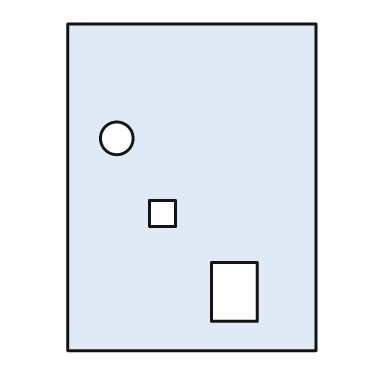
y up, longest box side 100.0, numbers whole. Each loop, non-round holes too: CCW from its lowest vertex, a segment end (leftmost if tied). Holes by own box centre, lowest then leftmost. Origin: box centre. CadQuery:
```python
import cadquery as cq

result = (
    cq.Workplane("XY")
    .moveTo(-38.0, -50.0)
    .lineTo(38.0, -50.0)
    .lineTo(38.0, 50.0)
    .lineTo(-38.0, 50.0)
    .close()
    .moveTo(6.0, -41.0)
    .lineTo(20.0, -41.0)
    .lineTo(20.0, -23.0)
    .lineTo(6.0, -23.0)
    .close()
    .moveTo(-13.0, -12.0)
    .lineTo(-5.0, -12.0)
    .lineTo(-5.0, -4.0)
    .lineTo(-13.0, -4.0)
    .close()
    .moveTo(-23.0, 15.0)
    .circle(5.0)
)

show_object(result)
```